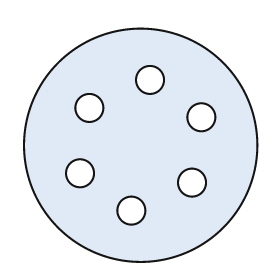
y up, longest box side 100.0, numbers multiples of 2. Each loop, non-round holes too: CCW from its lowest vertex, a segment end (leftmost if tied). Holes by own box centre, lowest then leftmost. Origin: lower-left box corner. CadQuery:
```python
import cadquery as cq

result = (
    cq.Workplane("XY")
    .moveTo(50.0, 50.0)
    .circle(50.0)
    .moveTo(46.0, 22.0)
    .circle(6.0)
    .moveTo(72.0, 34.0)
    .circle(6.0)
    .moveTo(24.0, 38.0)
    .circle(6.0)
    .moveTo(76.0, 62.0)
    .circle(6.0)
    .moveTo(28.0, 66.0)
    .circle(6.0)
    .moveTo(54.0, 78.0)
    .circle(6.0)
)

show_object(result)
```